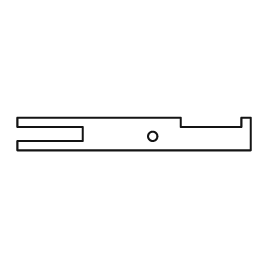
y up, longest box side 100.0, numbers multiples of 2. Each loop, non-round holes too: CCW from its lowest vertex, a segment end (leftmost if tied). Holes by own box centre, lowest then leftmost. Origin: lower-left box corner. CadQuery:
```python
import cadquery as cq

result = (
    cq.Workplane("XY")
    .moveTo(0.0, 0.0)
    .lineTo(100.0, 0.0)
    .lineTo(100.0, 14.0)
    .lineTo(96.0, 14.0)
    .lineTo(96.0, 10.0)
    .lineTo(70.0, 10.0)
    .lineTo(70.0, 14.0)
    .lineTo(0.0, 14.0)
    .lineTo(0.0, 10.0)
    .lineTo(28.0, 10.0)
    .lineTo(28.0, 4.0)
    .lineTo(0.0, 4.0)
    .close()
    .moveTo(58.0, 6.0)
    .circle(2.0)
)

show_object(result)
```